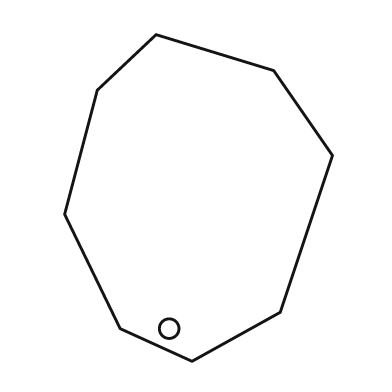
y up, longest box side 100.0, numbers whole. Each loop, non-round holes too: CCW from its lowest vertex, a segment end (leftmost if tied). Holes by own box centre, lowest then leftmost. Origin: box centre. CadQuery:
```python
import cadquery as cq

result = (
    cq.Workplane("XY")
    .moveTo(-2.0, -50.0)
    .lineTo(25.0, -35.0)
    .lineTo(41.0, 13.0)
    .lineTo(23.0, 39.0)
    .lineTo(-13.0, 50.0)
    .lineTo(-31.0, 33.0)
    .lineTo(-41.0, -5.0)
    .lineTo(-24.0, -40.0)
    .close()
    .moveTo(-9.0, -40.0)
    .circle(3.0)
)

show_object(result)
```